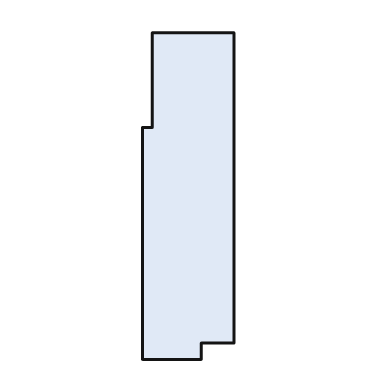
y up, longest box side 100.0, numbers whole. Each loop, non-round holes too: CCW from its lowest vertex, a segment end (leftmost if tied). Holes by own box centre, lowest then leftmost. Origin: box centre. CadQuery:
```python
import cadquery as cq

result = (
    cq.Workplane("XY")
    .moveTo(-14.0, -50.0)
    .lineTo(4.0, -50.0)
    .lineTo(4.0, -45.0)
    .lineTo(14.0, -45.0)
    .lineTo(14.0, 50.0)
    .lineTo(-11.0, 50.0)
    .lineTo(-11.0, 21.0)
    .lineTo(-14.0, 21.0)
    .close()
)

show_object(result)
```